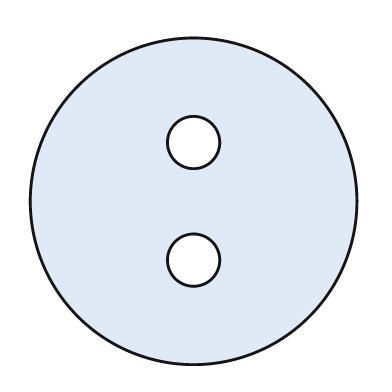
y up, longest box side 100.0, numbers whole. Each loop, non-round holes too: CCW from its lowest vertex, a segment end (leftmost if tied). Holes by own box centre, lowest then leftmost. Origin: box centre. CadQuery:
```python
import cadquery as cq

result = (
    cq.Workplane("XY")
    .moveTo(0.0, 0.0)
    .circle(50.0)
    .moveTo(0.0, -18.0)
    .circle(8.0)
    .moveTo(0.0, 18.0)
    .circle(8.0)
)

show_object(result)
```